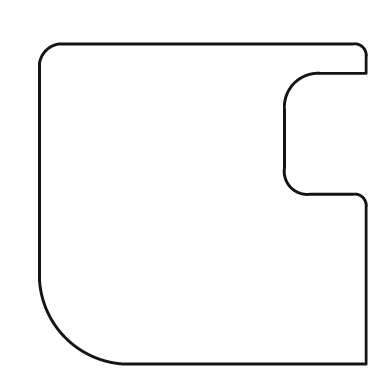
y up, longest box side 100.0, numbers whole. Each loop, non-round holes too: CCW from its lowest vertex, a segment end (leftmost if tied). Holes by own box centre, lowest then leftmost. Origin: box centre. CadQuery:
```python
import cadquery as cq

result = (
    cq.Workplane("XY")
    .moveTo(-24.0, -49.0)
    .lineTo(50.0, -49.0)
    .lineTo(50.0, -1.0)
    .threePointArc((49.0, 2.0), (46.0, 3.0))
    .lineTo(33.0, 3.0)
    .threePointArc((27.0, 5.0), (25.0, 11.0))
    .lineTo(25.0, 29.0)
    .threePointArc((28.0, 37.0), (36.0, 40.0))
    .lineTo(50.0, 40.0)
    .lineTo(50.0, 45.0)
    .threePointArc((49.0, 48.0), (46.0, 49.0))
    .lineTo(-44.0, 49.0)
    .threePointArc((-48.0, 47.0), (-50.0, 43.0))
    .lineTo(-50.0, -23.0)
    .threePointArc((-42.0, -41.0), (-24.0, -49.0))
    .close()
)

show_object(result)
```